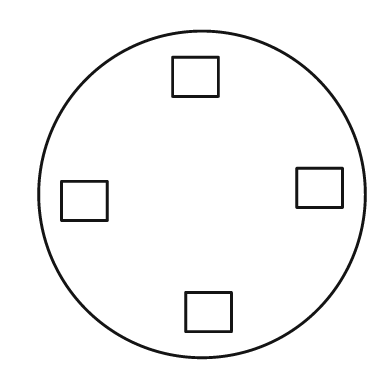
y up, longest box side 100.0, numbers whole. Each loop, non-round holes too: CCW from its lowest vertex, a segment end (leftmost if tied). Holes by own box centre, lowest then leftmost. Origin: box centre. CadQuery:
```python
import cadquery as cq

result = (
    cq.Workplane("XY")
    .moveTo(0.0, 0.0)
    .circle(50.0)
    .moveTo(-5.0, -42.0)
    .lineTo(9.0, -42.0)
    .lineTo(9.0, -30.0)
    .lineTo(-5.0, -30.0)
    .close()
    .moveTo(-43.0, -8.0)
    .lineTo(-29.0, -8.0)
    .lineTo(-29.0, 4.0)
    .lineTo(-43.0, 4.0)
    .close()
    .moveTo(29.0, -4.0)
    .lineTo(43.0, -4.0)
    .lineTo(43.0, 8.0)
    .lineTo(29.0, 8.0)
    .close()
    .moveTo(-9.0, 30.0)
    .lineTo(5.0, 30.0)
    .lineTo(5.0, 42.0)
    .lineTo(-9.0, 42.0)
    .close()
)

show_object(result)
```